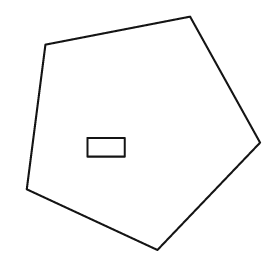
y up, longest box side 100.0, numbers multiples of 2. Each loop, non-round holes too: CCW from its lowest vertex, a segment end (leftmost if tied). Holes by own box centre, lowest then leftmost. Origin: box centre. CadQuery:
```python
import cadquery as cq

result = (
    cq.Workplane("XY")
    .moveTo(6.0, -50.0)
    .lineTo(50.0, -4.0)
    .lineTo(20.0, 50.0)
    .lineTo(-42.0, 38.0)
    .lineTo(-50.0, -24.0)
    .close()
    .moveTo(-24.0, -10.0)
    .lineTo(-8.0, -10.0)
    .lineTo(-8.0, -2.0)
    .lineTo(-24.0, -2.0)
    .close()
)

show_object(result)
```